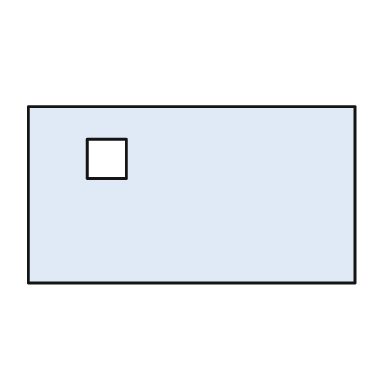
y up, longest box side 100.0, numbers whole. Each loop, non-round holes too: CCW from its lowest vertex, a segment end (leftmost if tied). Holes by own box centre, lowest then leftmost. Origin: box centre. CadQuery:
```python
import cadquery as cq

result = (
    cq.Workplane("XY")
    .moveTo(-50.0, -27.0)
    .lineTo(50.0, -27.0)
    .lineTo(50.0, 27.0)
    .lineTo(-50.0, 27.0)
    .close()
    .moveTo(-32.0, 5.0)
    .lineTo(-20.0, 5.0)
    .lineTo(-20.0, 17.0)
    .lineTo(-32.0, 17.0)
    .close()
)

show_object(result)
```